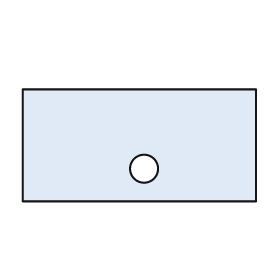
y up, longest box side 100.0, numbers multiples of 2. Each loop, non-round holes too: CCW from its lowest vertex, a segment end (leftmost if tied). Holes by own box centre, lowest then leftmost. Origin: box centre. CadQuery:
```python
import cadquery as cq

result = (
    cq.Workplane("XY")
    .moveTo(-50.0, -24.0)
    .lineTo(50.0, -24.0)
    .lineTo(50.0, 24.0)
    .lineTo(-50.0, 24.0)
    .close()
    .moveTo(2.0, -10.0)
    .circle(6.0)
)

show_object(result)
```